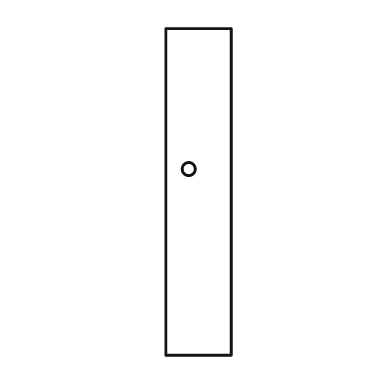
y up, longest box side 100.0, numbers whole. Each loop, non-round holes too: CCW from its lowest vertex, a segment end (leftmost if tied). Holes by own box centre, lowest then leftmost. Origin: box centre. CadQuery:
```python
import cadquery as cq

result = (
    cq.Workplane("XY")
    .moveTo(-10.0, -50.0)
    .lineTo(10.0, -50.0)
    .lineTo(10.0, 50.0)
    .lineTo(-10.0, 50.0)
    .close()
    .moveTo(-3.0, 7.0)
    .circle(2.0)
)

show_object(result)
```